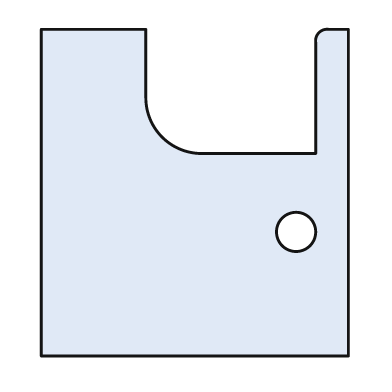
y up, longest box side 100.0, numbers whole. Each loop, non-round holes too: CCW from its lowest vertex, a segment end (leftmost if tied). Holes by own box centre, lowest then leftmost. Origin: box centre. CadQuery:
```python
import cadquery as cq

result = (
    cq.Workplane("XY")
    .moveTo(-47.0, -50.0)
    .lineTo(47.0, -50.0)
    .lineTo(47.0, 50.0)
    .lineTo(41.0, 50.0)
    .threePointArc((38.0, 49.0), (37.0, 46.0))
    .lineTo(37.0, 12.0)
    .lineTo(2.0, 12.0)
    .threePointArc((-10.0, 17.0), (-15.0, 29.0))
    .lineTo(-15.0, 50.0)
    .lineTo(-47.0, 50.0)
    .close()
    .moveTo(31.0, -12.0)
    .circle(6.0)
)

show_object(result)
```